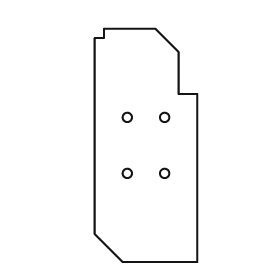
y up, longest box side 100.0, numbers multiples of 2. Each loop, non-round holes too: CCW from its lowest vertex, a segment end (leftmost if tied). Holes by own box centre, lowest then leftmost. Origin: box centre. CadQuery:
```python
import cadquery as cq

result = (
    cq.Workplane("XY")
    .moveTo(-10.0, -50.0)
    .lineTo(22.0, -50.0)
    .lineTo(22.0, 22.0)
    .lineTo(14.0, 22.0)
    .lineTo(14.0, 40.0)
    .lineTo(4.0, 50.0)
    .lineTo(-18.0, 50.0)
    .lineTo(-18.0, 46.0)
    .lineTo(-22.0, 46.0)
    .lineTo(-22.0, -38.0)
    .close()
    .moveTo(-8.0, -12.0)
    .circle(2.0)
    .moveTo(8.0, -12.0)
    .circle(2.0)
    .moveTo(-8.0, 12.0)
    .circle(2.0)
    .moveTo(8.0, 12.0)
    .circle(2.0)
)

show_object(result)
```